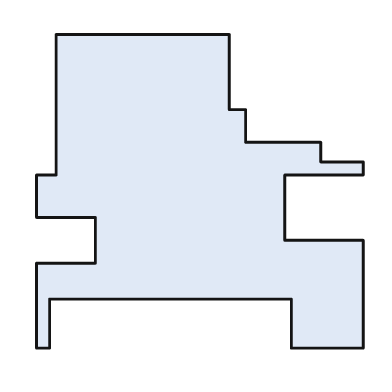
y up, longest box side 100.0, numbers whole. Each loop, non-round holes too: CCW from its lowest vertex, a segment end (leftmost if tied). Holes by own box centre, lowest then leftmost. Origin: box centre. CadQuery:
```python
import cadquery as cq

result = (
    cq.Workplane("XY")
    .moveTo(-50.0, -48.0)
    .lineTo(-46.0, -48.0)
    .lineTo(-46.0, -33.0)
    .lineTo(28.0, -33.0)
    .lineTo(28.0, -48.0)
    .lineTo(50.0, -48.0)
    .lineTo(50.0, -15.0)
    .lineTo(26.0, -15.0)
    .lineTo(26.0, 5.0)
    .lineTo(50.0, 5.0)
    .lineTo(50.0, 9.0)
    .lineTo(37.0, 9.0)
    .lineTo(37.0, 15.0)
    .lineTo(14.0, 15.0)
    .lineTo(14.0, 25.0)
    .lineTo(9.0, 25.0)
    .lineTo(9.0, 48.0)
    .lineTo(-44.0, 48.0)
    .lineTo(-44.0, 5.0)
    .lineTo(-50.0, 5.0)
    .lineTo(-50.0, -8.0)
    .lineTo(-32.0, -8.0)
    .lineTo(-32.0, -22.0)
    .lineTo(-50.0, -22.0)
    .close()
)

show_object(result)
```